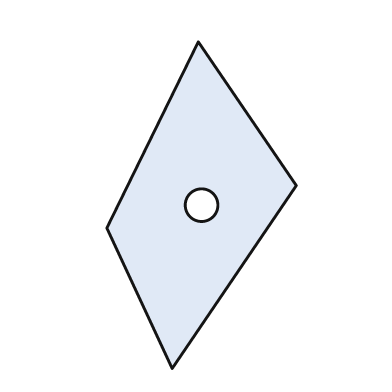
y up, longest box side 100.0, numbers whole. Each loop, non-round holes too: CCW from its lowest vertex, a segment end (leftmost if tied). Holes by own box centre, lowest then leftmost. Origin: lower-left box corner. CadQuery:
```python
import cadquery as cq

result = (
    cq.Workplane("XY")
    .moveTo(20.0, 0.0)
    .lineTo(58.0, 56.0)
    .lineTo(28.0, 100.0)
    .lineTo(0.0, 43.0)
    .close()
    .moveTo(29.0, 50.0)
    .circle(5.0)
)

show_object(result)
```